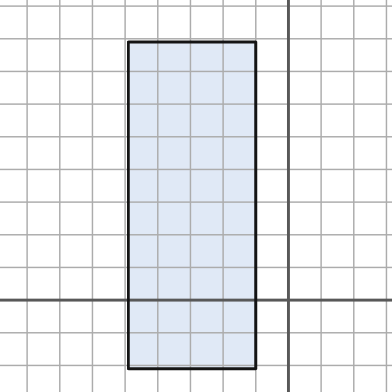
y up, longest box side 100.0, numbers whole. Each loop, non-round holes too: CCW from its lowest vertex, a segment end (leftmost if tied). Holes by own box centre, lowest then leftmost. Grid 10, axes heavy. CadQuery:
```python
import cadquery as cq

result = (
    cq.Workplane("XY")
    .moveTo(-49.0, -21.0)
    .lineTo(-10.0, -21.0)
    .lineTo(-10.0, 79.0)
    .lineTo(-49.0, 79.0)
    .close()
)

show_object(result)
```